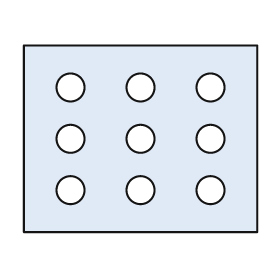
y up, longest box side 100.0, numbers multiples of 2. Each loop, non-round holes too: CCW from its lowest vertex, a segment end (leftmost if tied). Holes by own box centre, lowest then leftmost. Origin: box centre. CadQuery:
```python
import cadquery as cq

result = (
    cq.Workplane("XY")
    .moveTo(-50.0, -40.0)
    .lineTo(50.0, -40.0)
    .lineTo(50.0, 40.0)
    .lineTo(-50.0, 40.0)
    .close()
    .moveTo(-30.0, -22.0)
    .circle(6.0)
    .moveTo(0.0, -22.0)
    .circle(6.0)
    .moveTo(30.0, -22.0)
    .circle(6.0)
    .moveTo(-30.0, 0.0)
    .circle(6.0)
    .moveTo(0.0, 0.0)
    .circle(6.0)
    .moveTo(30.0, 0.0)
    .circle(6.0)
    .moveTo(-30.0, 22.0)
    .circle(6.0)
    .moveTo(0.0, 22.0)
    .circle(6.0)
    .moveTo(30.0, 22.0)
    .circle(6.0)
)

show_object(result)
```